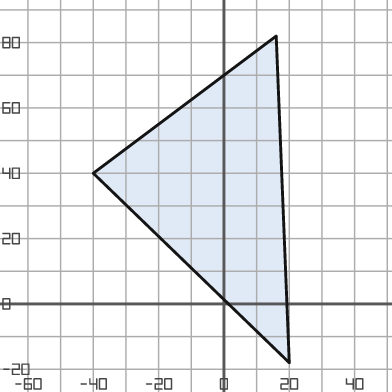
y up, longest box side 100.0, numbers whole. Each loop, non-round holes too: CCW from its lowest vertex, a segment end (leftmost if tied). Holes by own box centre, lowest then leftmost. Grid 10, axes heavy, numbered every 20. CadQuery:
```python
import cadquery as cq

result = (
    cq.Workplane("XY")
    .moveTo(20.0, -18.0)
    .lineTo(16.0, 82.0)
    .lineTo(-40.0, 40.0)
    .close()
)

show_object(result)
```